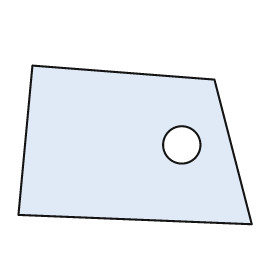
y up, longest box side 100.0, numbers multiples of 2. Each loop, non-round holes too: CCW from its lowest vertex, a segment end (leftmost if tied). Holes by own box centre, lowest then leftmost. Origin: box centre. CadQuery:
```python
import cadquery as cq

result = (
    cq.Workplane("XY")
    .moveTo(50.0, -34.0)
    .lineTo(34.0, 28.0)
    .lineTo(-44.0, 34.0)
    .lineTo(-50.0, -30.0)
    .close()
    .moveTo(20.0, 0.0)
    .circle(8.0)
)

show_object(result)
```